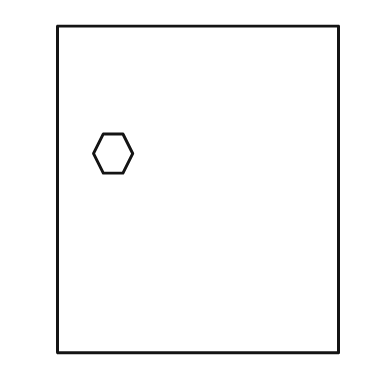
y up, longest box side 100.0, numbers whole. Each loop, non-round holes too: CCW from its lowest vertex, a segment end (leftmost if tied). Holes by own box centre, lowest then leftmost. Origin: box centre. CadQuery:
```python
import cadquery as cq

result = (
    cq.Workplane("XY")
    .moveTo(-43.0, -50.0)
    .lineTo(43.0, -50.0)
    .lineTo(43.0, 50.0)
    .lineTo(-43.0, 50.0)
    .close()
    .moveTo(-29.0, 5.0)
    .lineTo(-23.0, 5.0)
    .lineTo(-20.0, 11.0)
    .lineTo(-23.0, 17.0)
    .lineTo(-29.0, 17.0)
    .lineTo(-32.0, 11.0)
    .close()
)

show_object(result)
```